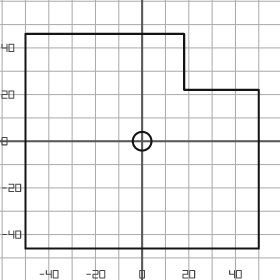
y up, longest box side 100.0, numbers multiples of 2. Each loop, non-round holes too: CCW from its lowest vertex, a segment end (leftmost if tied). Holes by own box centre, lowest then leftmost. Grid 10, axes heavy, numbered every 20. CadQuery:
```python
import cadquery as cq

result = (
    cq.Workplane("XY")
    .moveTo(-50.0, -46.0)
    .lineTo(50.0, -46.0)
    .lineTo(50.0, 22.0)
    .lineTo(18.0, 22.0)
    .lineTo(18.0, 46.0)
    .lineTo(-50.0, 46.0)
    .close()
    .moveTo(0.0, 0.0)
    .circle(4.0)
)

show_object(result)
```